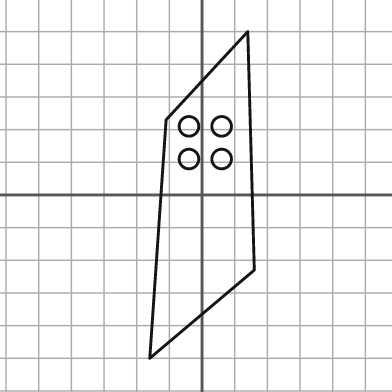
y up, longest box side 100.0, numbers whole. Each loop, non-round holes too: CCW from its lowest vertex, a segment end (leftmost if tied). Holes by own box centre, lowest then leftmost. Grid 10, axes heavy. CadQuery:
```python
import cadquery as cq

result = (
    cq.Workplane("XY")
    .moveTo(-16.0, -50.0)
    .lineTo(16.0, -23.0)
    .lineTo(14.0, 50.0)
    .lineTo(-11.0, 23.0)
    .close()
    .moveTo(-4.0, 11.0)
    .circle(3.0)
    .moveTo(6.0, 11.0)
    .circle(3.0)
    .moveTo(-4.0, 21.0)
    .circle(3.0)
    .moveTo(6.0, 21.0)
    .circle(3.0)
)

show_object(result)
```